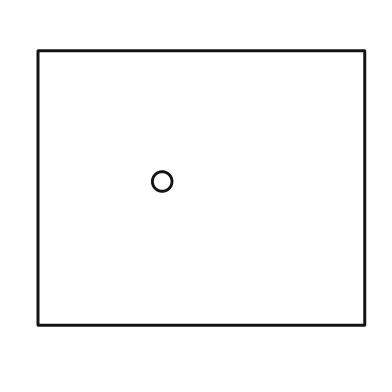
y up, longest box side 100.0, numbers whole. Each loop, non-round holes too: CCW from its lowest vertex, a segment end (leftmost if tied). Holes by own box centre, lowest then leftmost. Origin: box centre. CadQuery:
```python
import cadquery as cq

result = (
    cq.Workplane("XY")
    .moveTo(-50.0, -42.0)
    .lineTo(50.0, -42.0)
    .lineTo(50.0, 42.0)
    .lineTo(-50.0, 42.0)
    .close()
    .moveTo(-12.0, 2.0)
    .circle(3.0)
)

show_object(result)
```